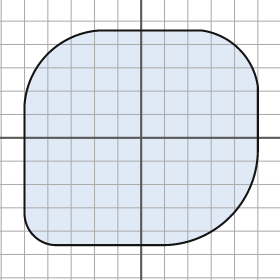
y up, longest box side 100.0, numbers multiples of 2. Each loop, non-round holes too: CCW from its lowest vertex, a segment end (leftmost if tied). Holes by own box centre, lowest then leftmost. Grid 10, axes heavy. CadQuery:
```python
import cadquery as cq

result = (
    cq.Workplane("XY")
    .moveTo(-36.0, -46.0)
    .lineTo(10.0, -46.0)
    .threePointArc((38.0, -34.0), (50.0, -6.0))
    .lineTo(50.0, 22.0)
    .threePointArc((42.0, 38.0), (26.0, 46.0))
    .lineTo(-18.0, 46.0)
    .threePointArc((-40.0, 36.0), (-50.0, 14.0))
    .lineTo(-50.0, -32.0)
    .threePointArc((-46.0, -42.0), (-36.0, -46.0))
    .close()
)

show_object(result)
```